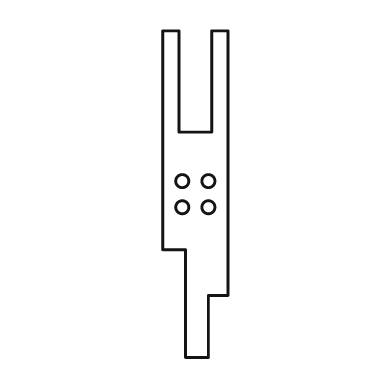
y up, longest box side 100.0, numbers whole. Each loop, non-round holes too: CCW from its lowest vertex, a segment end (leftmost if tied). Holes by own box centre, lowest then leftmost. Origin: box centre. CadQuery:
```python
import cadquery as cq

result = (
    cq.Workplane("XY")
    .moveTo(-3.0, -50.0)
    .lineTo(4.0, -50.0)
    .lineTo(4.0, -31.0)
    .lineTo(10.0, -31.0)
    .lineTo(10.0, 50.0)
    .lineTo(5.0, 50.0)
    .lineTo(5.0, 19.0)
    .lineTo(-5.0, 19.0)
    .lineTo(-5.0, 50.0)
    .lineTo(-10.0, 50.0)
    .lineTo(-10.0, -17.0)
    .lineTo(-3.0, -17.0)
    .close()
    .moveTo(-4.0, -4.0)
    .circle(2.0)
    .moveTo(4.0, -4.0)
    .circle(2.0)
    .moveTo(-4.0, 4.0)
    .circle(2.0)
    .moveTo(4.0, 4.0)
    .circle(2.0)
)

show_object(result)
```